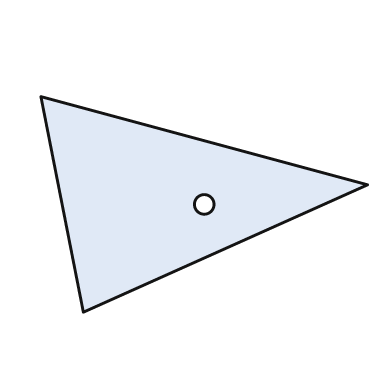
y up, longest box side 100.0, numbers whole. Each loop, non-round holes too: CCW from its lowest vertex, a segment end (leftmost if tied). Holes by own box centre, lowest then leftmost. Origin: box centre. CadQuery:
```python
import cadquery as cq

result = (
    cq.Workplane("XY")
    .moveTo(-37.0, -33.0)
    .lineTo(50.0, 6.0)
    .lineTo(-50.0, 33.0)
    .close()
    .moveTo(0.0, 0.0)
    .circle(3.0)
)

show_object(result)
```